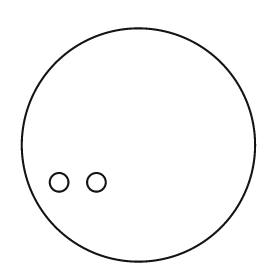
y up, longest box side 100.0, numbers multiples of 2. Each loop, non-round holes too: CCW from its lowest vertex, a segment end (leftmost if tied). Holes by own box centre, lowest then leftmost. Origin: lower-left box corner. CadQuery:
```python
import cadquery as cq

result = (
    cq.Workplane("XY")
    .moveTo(50.0, 50.0)
    .circle(50.0)
    .moveTo(16.0, 34.0)
    .circle(4.0)
    .moveTo(32.0, 34.0)
    .circle(4.0)
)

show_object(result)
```